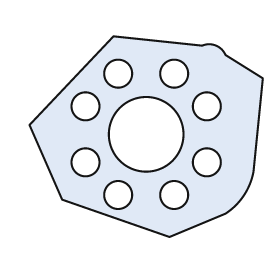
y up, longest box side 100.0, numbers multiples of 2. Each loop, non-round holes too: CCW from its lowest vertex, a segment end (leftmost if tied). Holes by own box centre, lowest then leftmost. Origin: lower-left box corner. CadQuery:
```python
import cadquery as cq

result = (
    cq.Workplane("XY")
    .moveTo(60.0, 0.0)
    .lineTo(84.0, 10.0)
    .threePointArc((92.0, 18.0), (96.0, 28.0))
    .lineTo(100.0, 68.0)
    .lineTo(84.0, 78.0)
    .threePointArc((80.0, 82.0), (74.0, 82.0))
    .lineTo(36.0, 86.0)
    .lineTo(0.0, 48.0)
    .lineTo(14.0, 16.0)
    .close()
    .moveTo(38.0, 18.0)
    .circle(6.0)
    .moveTo(62.0, 18.0)
    .circle(6.0)
    .moveTo(24.0, 32.0)
    .circle(6.0)
    .moveTo(76.0, 32.0)
    .circle(6.0)
    .moveTo(50.0, 44.0)
    .circle(16.0)
    .moveTo(24.0, 56.0)
    .circle(6.0)
    .moveTo(76.0, 56.0)
    .circle(6.0)
    .moveTo(38.0, 70.0)
    .circle(6.0)
    .moveTo(62.0, 70.0)
    .circle(6.0)
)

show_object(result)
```